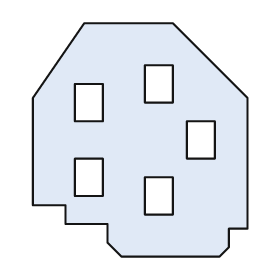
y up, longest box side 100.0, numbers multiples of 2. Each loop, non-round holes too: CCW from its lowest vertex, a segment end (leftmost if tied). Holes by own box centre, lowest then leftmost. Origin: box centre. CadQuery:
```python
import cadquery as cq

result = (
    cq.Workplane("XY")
    .moveTo(-8.0, -50.0)
    .lineTo(34.0, -50.0)
    .lineTo(38.0, -46.0)
    .lineTo(38.0, -38.0)
    .lineTo(46.0, -38.0)
    .lineTo(46.0, 18.0)
    .lineTo(14.0, 50.0)
    .lineTo(-24.0, 50.0)
    .lineTo(-46.0, 18.0)
    .lineTo(-46.0, -28.0)
    .lineTo(-32.0, -28.0)
    .lineTo(-32.0, -36.0)
    .lineTo(-14.0, -36.0)
    .lineTo(-14.0, -44.0)
    .close()
    .moveTo(2.0, -32.0)
    .lineTo(14.0, -32.0)
    .lineTo(14.0, -16.0)
    .lineTo(2.0, -16.0)
    .close()
    .moveTo(-28.0, -24.0)
    .lineTo(-16.0, -24.0)
    .lineTo(-16.0, -8.0)
    .lineTo(-28.0, -8.0)
    .close()
    .moveTo(20.0, -8.0)
    .lineTo(32.0, -8.0)
    .lineTo(32.0, 8.0)
    .lineTo(20.0, 8.0)
    .close()
    .moveTo(-28.0, 8.0)
    .lineTo(-16.0, 8.0)
    .lineTo(-16.0, 24.0)
    .lineTo(-28.0, 24.0)
    .close()
    .moveTo(2.0, 16.0)
    .lineTo(14.0, 16.0)
    .lineTo(14.0, 32.0)
    .lineTo(2.0, 32.0)
    .close()
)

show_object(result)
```